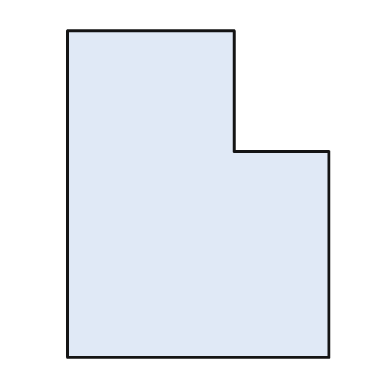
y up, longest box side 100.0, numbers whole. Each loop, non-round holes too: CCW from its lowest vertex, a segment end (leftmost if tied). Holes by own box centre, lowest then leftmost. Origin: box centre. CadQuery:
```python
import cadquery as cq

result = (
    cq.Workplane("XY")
    .moveTo(-40.0, -50.0)
    .lineTo(40.0, -50.0)
    .lineTo(40.0, 13.0)
    .lineTo(11.0, 13.0)
    .lineTo(11.0, 50.0)
    .lineTo(-40.0, 50.0)
    .close()
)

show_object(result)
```